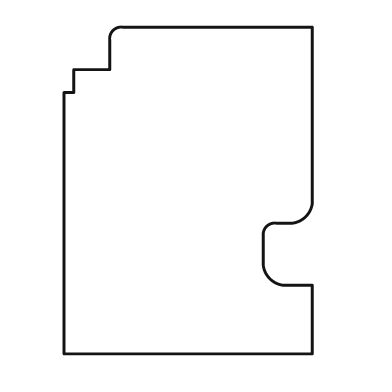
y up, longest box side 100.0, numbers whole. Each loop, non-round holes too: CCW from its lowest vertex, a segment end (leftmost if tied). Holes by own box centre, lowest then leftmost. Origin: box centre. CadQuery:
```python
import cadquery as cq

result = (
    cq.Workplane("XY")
    .moveTo(-38.0, -50.0)
    .lineTo(38.0, -50.0)
    .lineTo(38.0, -29.0)
    .lineTo(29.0, -29.0)
    .threePointArc((25.0, -27.0), (23.0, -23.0))
    .lineTo(23.0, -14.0)
    .threePointArc((24.0, -11.0), (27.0, -10.0))
    .lineTo(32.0, -10.0)
    .threePointArc((36.0, -8.0), (38.0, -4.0))
    .lineTo(38.0, 50.0)
    .lineTo(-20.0, 50.0)
    .threePointArc((-23.0, 49.0), (-24.0, 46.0))
    .lineTo(-24.0, 37.0)
    .lineTo(-35.0, 37.0)
    .lineTo(-35.0, 30.0)
    .lineTo(-38.0, 30.0)
    .close()
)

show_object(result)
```